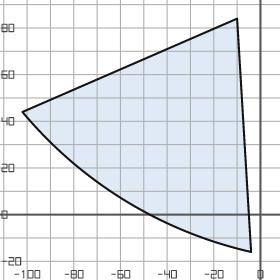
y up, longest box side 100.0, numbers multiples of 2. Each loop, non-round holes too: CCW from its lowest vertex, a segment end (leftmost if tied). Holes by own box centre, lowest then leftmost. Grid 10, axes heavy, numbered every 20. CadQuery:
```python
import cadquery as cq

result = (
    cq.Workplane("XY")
    .moveTo(-4.0, -16.0)
    .lineTo(-10.0, 84.0)
    .lineTo(-102.0, 44.0)
    .threePointArc((-58.0, 6.0), (-4.0, -16.0))
    .close()
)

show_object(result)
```